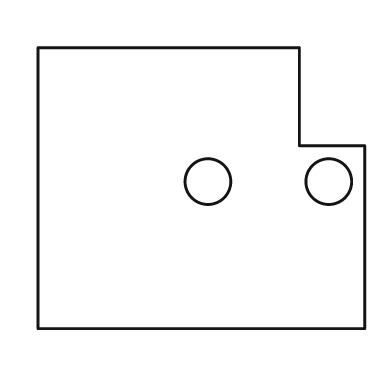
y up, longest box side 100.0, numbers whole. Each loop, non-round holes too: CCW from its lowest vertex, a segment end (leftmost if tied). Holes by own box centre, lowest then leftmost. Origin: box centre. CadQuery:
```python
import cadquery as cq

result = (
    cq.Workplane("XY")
    .moveTo(-50.0, -43.0)
    .lineTo(50.0, -43.0)
    .lineTo(50.0, 13.0)
    .lineTo(30.0, 13.0)
    .lineTo(30.0, 43.0)
    .lineTo(-50.0, 43.0)
    .close()
    .moveTo(2.0, 2.0)
    .circle(7.0)
    .moveTo(39.0, 2.0)
    .circle(7.0)
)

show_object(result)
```